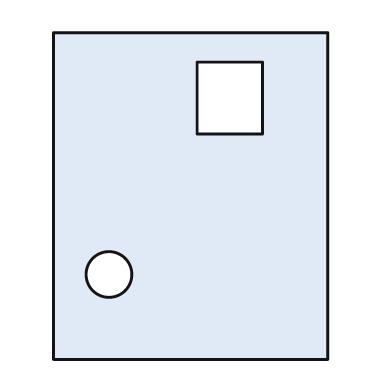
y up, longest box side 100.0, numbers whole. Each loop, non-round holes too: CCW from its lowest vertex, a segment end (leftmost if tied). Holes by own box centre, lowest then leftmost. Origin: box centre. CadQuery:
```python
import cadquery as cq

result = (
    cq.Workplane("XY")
    .moveTo(-42.0, -50.0)
    .lineTo(42.0, -50.0)
    .lineTo(42.0, 50.0)
    .lineTo(-42.0, 50.0)
    .close()
    .moveTo(-25.0, -24.0)
    .circle(7.0)
    .moveTo(2.0, 19.0)
    .lineTo(22.0, 19.0)
    .lineTo(22.0, 41.0)
    .lineTo(2.0, 41.0)
    .close()
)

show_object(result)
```